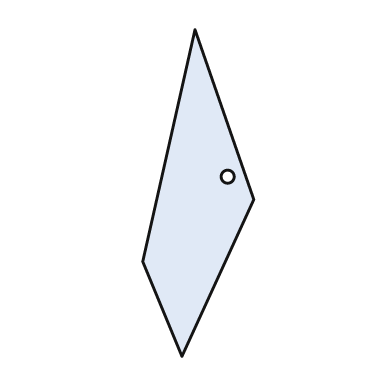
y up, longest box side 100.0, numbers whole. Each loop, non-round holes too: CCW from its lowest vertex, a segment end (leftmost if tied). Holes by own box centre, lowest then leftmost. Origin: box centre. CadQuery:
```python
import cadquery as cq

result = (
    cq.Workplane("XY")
    .moveTo(-5.0, -50.0)
    .lineTo(17.0, -2.0)
    .lineTo(-1.0, 50.0)
    .lineTo(-17.0, -21.0)
    .close()
    .moveTo(9.0, 5.0)
    .circle(2.0)
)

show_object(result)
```